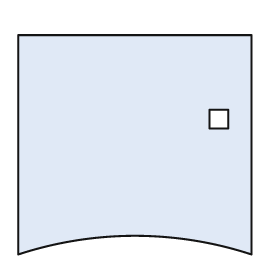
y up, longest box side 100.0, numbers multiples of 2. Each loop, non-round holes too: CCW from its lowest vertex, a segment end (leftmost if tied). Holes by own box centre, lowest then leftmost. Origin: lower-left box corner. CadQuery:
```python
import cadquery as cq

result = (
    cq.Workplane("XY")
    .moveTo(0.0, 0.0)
    .threePointArc((50.0, 8.0), (100.0, 0.0))
    .lineTo(100.0, 94.0)
    .lineTo(0.0, 94.0)
    .close()
    .moveTo(82.0, 54.0)
    .lineTo(90.0, 54.0)
    .lineTo(90.0, 62.0)
    .lineTo(82.0, 62.0)
    .close()
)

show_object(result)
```